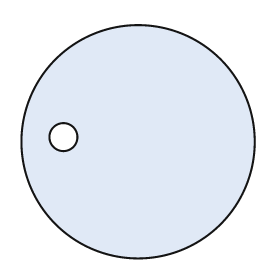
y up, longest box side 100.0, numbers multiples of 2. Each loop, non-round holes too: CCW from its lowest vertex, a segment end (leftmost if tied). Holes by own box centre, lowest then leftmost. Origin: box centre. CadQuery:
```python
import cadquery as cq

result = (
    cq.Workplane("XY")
    .moveTo(0.0, 0.0)
    .circle(50.0)
    .moveTo(-32.0, 2.0)
    .circle(6.0)
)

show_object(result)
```